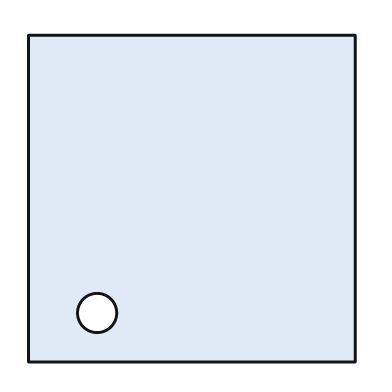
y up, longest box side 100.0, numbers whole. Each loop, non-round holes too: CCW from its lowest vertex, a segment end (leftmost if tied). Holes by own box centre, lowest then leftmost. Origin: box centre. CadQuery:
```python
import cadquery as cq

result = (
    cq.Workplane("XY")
    .moveTo(-50.0, -50.0)
    .lineTo(50.0, -50.0)
    .lineTo(50.0, 50.0)
    .lineTo(-50.0, 50.0)
    .close()
    .moveTo(-29.0, -35.0)
    .circle(6.0)
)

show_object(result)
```